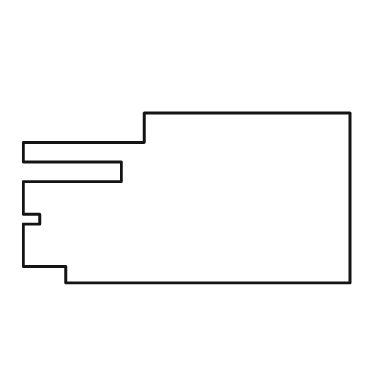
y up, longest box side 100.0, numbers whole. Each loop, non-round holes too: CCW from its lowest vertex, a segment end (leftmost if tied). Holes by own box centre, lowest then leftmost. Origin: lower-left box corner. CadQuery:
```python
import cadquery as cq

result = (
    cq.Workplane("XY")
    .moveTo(13.0, 0.0)
    .lineTo(100.0, 0.0)
    .lineTo(100.0, 52.0)
    .lineTo(37.0, 52.0)
    .lineTo(37.0, 43.0)
    .lineTo(0.0, 43.0)
    .lineTo(0.0, 37.0)
    .lineTo(30.0, 37.0)
    .lineTo(30.0, 31.0)
    .lineTo(0.0, 31.0)
    .lineTo(0.0, 21.0)
    .lineTo(5.0, 21.0)
    .lineTo(5.0, 18.0)
    .lineTo(0.0, 18.0)
    .lineTo(0.0, 5.0)
    .lineTo(13.0, 5.0)
    .close()
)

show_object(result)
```